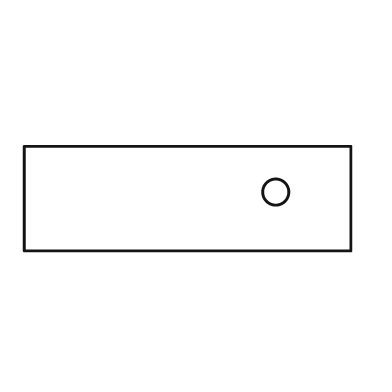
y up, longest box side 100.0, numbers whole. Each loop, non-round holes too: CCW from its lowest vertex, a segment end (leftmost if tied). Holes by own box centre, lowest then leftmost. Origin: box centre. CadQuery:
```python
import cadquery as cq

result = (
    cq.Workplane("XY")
    .moveTo(-50.0, -16.0)
    .lineTo(50.0, -16.0)
    .lineTo(50.0, 16.0)
    .lineTo(-50.0, 16.0)
    .close()
    .moveTo(27.0, 2.0)
    .circle(4.0)
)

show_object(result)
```